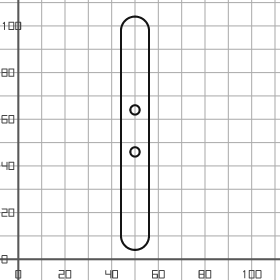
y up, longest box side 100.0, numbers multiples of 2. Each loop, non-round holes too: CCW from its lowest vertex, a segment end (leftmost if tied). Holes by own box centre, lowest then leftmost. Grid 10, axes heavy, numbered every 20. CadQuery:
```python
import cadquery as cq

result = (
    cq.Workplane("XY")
    .moveTo(44.0, 10.0)
    .threePointArc((50.0, 4.0), (56.0, 10.0))
    .lineTo(56.0, 98.0)
    .threePointArc((50.0, 104.0), (44.0, 98.0))
    .close()
    .moveTo(50.0, 46.0)
    .circle(2.0)
    .moveTo(50.0, 64.0)
    .circle(2.0)
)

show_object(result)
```